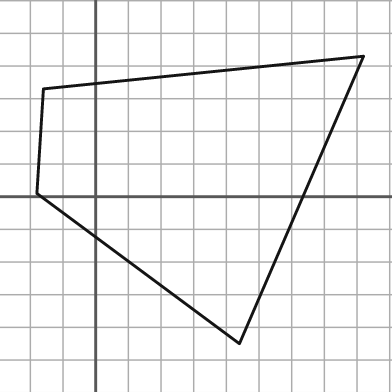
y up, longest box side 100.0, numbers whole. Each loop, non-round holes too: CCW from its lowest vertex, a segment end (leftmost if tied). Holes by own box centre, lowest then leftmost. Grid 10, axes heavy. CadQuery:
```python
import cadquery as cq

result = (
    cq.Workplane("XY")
    .moveTo(44.0, -45.0)
    .lineTo(82.0, 43.0)
    .lineTo(-16.0, 33.0)
    .lineTo(-18.0, 1.0)
    .close()
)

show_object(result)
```